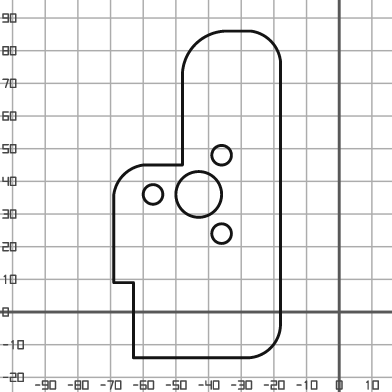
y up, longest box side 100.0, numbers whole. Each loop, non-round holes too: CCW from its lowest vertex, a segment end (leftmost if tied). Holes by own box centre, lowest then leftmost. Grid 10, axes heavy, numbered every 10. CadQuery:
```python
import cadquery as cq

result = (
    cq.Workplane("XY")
    .moveTo(-63.0, -14.0)
    .lineTo(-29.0, -14.0)
    .threePointArc((-21.0, -11.0), (-18.0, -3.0))
    .lineTo(-18.0, 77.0)
    .threePointArc((-21.0, 83.0), (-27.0, 86.0))
    .lineTo(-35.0, 86.0)
    .threePointArc((-44.0, 82.0), (-48.0, 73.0))
    .lineTo(-48.0, 45.0)
    .lineTo(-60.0, 45.0)
    .threePointArc((-66.0, 42.0), (-69.0, 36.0))
    .lineTo(-69.0, 9.0)
    .lineTo(-63.0, 9.0)
    .close()
    .moveTo(-36.0, 24.0)
    .circle(3.0)
    .moveTo(-57.0, 36.0)
    .circle(3.0)
    .moveTo(-43.0, 36.0)
    .circle(7.0)
    .moveTo(-36.0, 48.0)
    .circle(3.0)
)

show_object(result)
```